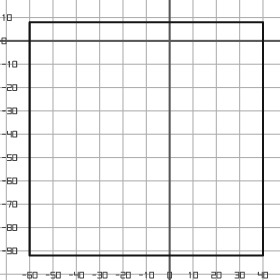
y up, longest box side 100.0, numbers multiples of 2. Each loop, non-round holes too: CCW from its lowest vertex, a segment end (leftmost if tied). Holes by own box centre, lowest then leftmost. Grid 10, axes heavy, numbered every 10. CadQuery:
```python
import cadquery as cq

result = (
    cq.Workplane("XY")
    .moveTo(-60.0, -92.0)
    .lineTo(40.0, -92.0)
    .lineTo(40.0, 8.0)
    .lineTo(-60.0, 8.0)
    .close()
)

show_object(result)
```